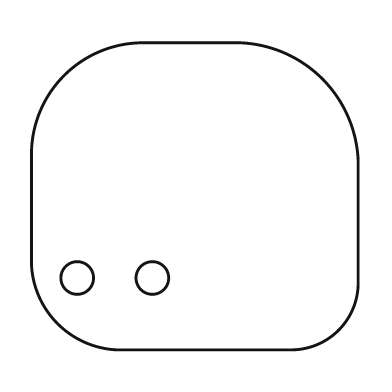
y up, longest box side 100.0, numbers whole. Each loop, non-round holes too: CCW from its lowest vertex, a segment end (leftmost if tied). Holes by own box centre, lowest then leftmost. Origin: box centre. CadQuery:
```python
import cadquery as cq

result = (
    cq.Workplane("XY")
    .moveTo(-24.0, -47.0)
    .lineTo(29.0, -47.0)
    .threePointArc((44.0, -41.0), (50.0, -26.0))
    .lineTo(50.0, 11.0)
    .threePointArc((39.0, 36.0), (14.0, 47.0))
    .lineTo(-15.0, 47.0)
    .threePointArc((-40.0, 37.0), (-50.0, 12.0))
    .lineTo(-50.0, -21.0)
    .threePointArc((-42.0, -39.0), (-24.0, -47.0))
    .close()
    .moveTo(-36.0, -25.0)
    .circle(5.0)
    .moveTo(-13.0, -25.0)
    .circle(5.0)
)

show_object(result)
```